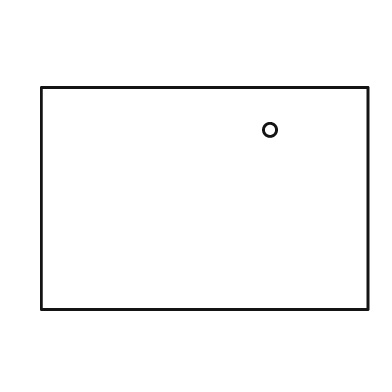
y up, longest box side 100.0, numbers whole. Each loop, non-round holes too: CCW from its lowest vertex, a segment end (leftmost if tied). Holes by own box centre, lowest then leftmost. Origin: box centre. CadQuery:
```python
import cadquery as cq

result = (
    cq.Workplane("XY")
    .moveTo(-50.0, -34.0)
    .lineTo(50.0, -34.0)
    .lineTo(50.0, 34.0)
    .lineTo(-50.0, 34.0)
    .close()
    .moveTo(20.0, 21.0)
    .circle(2.0)
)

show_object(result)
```